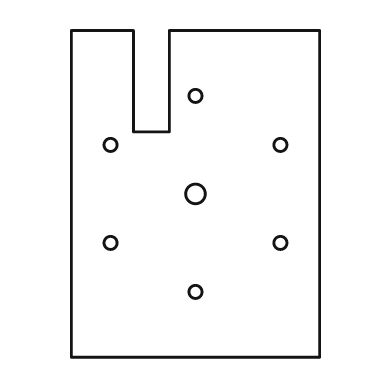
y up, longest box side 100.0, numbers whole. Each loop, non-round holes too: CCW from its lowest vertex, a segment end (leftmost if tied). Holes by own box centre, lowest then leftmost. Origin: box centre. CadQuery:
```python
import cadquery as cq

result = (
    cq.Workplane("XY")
    .moveTo(-38.0, -50.0)
    .lineTo(38.0, -50.0)
    .lineTo(38.0, 50.0)
    .lineTo(-8.0, 50.0)
    .lineTo(-8.0, 19.0)
    .lineTo(-19.0, 19.0)
    .lineTo(-19.0, 50.0)
    .lineTo(-38.0, 50.0)
    .close()
    .moveTo(0.0, -30.0)
    .circle(2.0)
    .moveTo(-26.0, -15.0)
    .circle(2.0)
    .moveTo(26.0, -15.0)
    .circle(2.0)
    .moveTo(0.0, 0.0)
    .circle(3.0)
    .moveTo(-26.0, 15.0)
    .circle(2.0)
    .moveTo(26.0, 15.0)
    .circle(2.0)
    .moveTo(0.0, 30.0)
    .circle(2.0)
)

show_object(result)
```